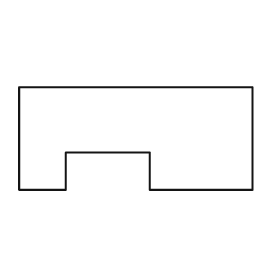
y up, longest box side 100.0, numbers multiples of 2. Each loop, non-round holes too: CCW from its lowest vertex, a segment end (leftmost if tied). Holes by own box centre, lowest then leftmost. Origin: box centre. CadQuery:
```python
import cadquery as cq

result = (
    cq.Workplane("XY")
    .moveTo(-50.0, -22.0)
    .lineTo(-30.0, -22.0)
    .lineTo(-30.0, -6.0)
    .lineTo(6.0, -6.0)
    .lineTo(6.0, -22.0)
    .lineTo(50.0, -22.0)
    .lineTo(50.0, 22.0)
    .lineTo(-50.0, 22.0)
    .close()
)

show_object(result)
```